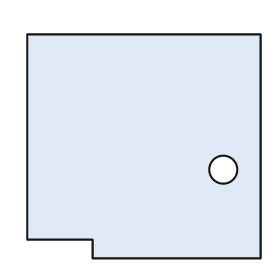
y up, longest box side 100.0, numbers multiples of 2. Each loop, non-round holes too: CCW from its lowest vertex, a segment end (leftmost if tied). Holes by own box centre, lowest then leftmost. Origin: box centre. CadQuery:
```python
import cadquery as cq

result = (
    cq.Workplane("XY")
    .moveTo(-22.0, -48.0)
    .lineTo(50.0, -48.0)
    .lineTo(50.0, 48.0)
    .lineTo(-50.0, 48.0)
    .lineTo(-50.0, -40.0)
    .lineTo(-22.0, -40.0)
    .close()
    .moveTo(34.0, -10.0)
    .circle(6.0)
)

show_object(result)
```